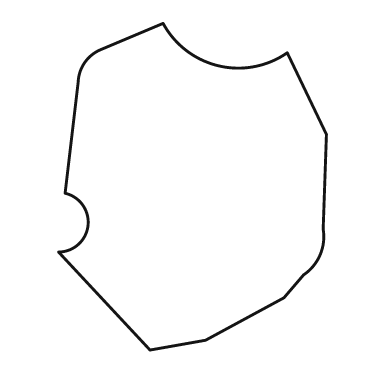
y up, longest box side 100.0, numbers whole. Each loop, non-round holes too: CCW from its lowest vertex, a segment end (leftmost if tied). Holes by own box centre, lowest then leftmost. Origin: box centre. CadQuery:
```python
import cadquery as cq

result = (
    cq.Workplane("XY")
    .moveTo(-13.0, -50.0)
    .lineTo(4.0, -47.0)
    .lineTo(28.0, -34.0)
    .lineTo(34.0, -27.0)
    .threePointArc((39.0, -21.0), (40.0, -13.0))
    .lineTo(41.0, 16.0)
    .lineTo(29.0, 41.0)
    .threePointArc((8.0, 37.0), (-9.0, 50.0))
    .lineTo(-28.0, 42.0)
    .threePointArc((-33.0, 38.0), (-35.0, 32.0))
    .lineTo(-39.0, -2.0)
    .threePointArc((-32.0, -12.0), (-41.0, -20.0))
    .close()
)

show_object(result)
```